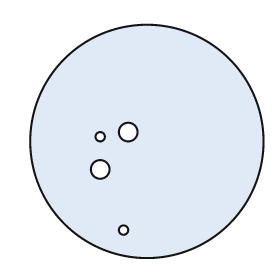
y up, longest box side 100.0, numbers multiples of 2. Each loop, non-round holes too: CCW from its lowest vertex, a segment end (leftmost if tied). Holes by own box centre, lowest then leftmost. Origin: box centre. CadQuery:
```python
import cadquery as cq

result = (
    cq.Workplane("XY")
    .moveTo(0.0, 0.0)
    .circle(50.0)
    .moveTo(-10.0, -38.0)
    .circle(2.0)
    .moveTo(-20.0, -12.0)
    .circle(4.0)
    .moveTo(-20.0, 2.0)
    .circle(2.0)
    .moveTo(-8.0, 4.0)
    .circle(4.0)
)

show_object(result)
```